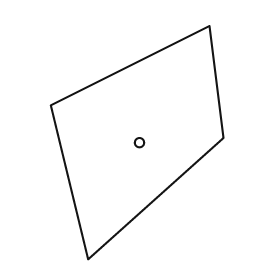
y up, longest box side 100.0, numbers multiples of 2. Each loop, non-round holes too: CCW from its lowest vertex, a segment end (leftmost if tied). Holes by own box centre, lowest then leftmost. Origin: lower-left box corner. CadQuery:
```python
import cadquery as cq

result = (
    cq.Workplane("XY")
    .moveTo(16.0, 0.0)
    .lineTo(74.0, 52.0)
    .lineTo(68.0, 100.0)
    .lineTo(0.0, 66.0)
    .close()
    .moveTo(38.0, 50.0)
    .circle(2.0)
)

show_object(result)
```